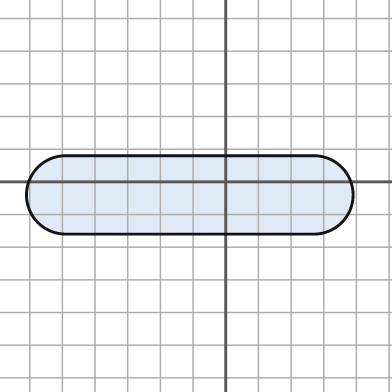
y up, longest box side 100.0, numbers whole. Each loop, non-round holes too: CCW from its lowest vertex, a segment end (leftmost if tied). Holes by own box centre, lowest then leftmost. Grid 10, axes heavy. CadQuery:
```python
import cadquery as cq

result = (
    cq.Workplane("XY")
    .moveTo(-49.0, -16.0)
    .lineTo(27.0, -16.0)
    .threePointArc((39.0, -4.0), (27.0, 8.0))
    .lineTo(-49.0, 8.0)
    .threePointArc((-61.0, -4.0), (-49.0, -16.0))
    .close()
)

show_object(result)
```